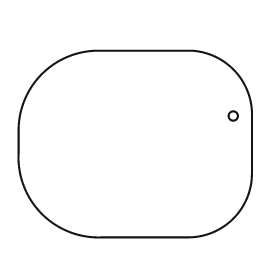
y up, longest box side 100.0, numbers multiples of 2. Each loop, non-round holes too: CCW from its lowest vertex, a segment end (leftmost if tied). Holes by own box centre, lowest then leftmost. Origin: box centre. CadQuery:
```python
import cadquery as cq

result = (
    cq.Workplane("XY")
    .moveTo(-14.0, -40.0)
    .lineTo(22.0, -40.0)
    .threePointArc((42.0, -32.0), (50.0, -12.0))
    .lineTo(50.0, 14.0)
    .threePointArc((42.0, 32.0), (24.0, 40.0))
    .lineTo(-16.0, 40.0)
    .threePointArc((-40.0, 30.0), (-50.0, 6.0))
    .lineTo(-50.0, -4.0)
    .threePointArc((-40.0, -30.0), (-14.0, -40.0))
    .close()
    .moveTo(42.0, 12.0)
    .circle(2.0)
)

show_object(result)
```